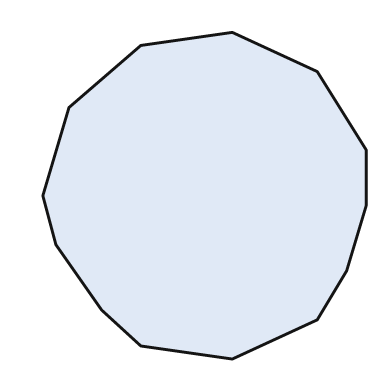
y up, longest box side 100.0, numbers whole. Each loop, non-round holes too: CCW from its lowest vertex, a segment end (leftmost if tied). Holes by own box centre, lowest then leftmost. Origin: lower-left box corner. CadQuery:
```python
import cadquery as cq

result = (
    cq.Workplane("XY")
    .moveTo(58.0, 0.0)
    .lineTo(84.0, 12.0)
    .lineTo(93.0, 27.0)
    .lineTo(99.0, 47.0)
    .lineTo(99.0, 64.0)
    .lineTo(84.0, 88.0)
    .lineTo(58.0, 100.0)
    .lineTo(30.0, 96.0)
    .lineTo(8.0, 77.0)
    .lineTo(0.0, 50.0)
    .lineTo(4.0, 35.0)
    .lineTo(18.0, 15.0)
    .lineTo(30.0, 4.0)
    .close()
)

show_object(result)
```